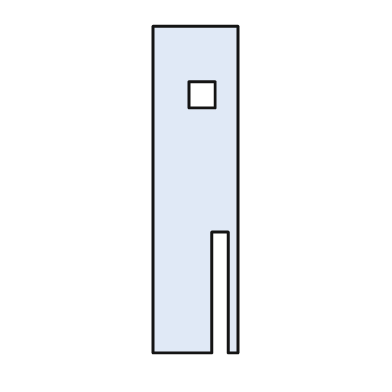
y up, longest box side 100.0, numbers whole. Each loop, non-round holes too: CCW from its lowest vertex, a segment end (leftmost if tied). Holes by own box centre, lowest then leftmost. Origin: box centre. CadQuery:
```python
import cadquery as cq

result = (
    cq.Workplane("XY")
    .moveTo(-13.0, -50.0)
    .lineTo(5.0, -50.0)
    .lineTo(5.0, -13.0)
    .lineTo(10.0, -13.0)
    .lineTo(10.0, -50.0)
    .lineTo(13.0, -50.0)
    .lineTo(13.0, 50.0)
    .lineTo(-13.0, 50.0)
    .close()
    .moveTo(-2.0, 25.0)
    .lineTo(6.0, 25.0)
    .lineTo(6.0, 33.0)
    .lineTo(-2.0, 33.0)
    .close()
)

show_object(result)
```